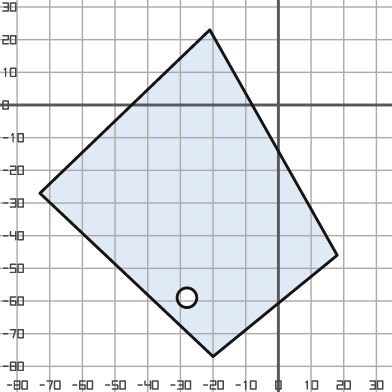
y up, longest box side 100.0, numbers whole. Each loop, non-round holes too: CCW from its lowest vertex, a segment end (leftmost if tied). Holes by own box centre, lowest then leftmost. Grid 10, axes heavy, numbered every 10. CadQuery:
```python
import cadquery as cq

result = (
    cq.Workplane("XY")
    .moveTo(-20.0, -77.0)
    .lineTo(18.0, -46.0)
    .lineTo(-21.0, 23.0)
    .lineTo(-73.0, -27.0)
    .close()
    .moveTo(-28.0, -59.0)
    .circle(3.0)
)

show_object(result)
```